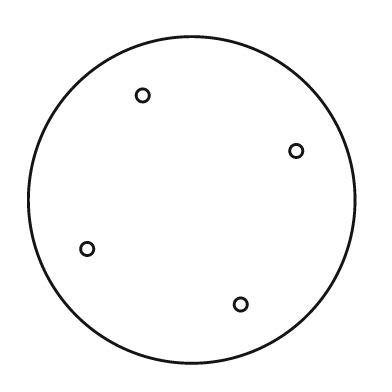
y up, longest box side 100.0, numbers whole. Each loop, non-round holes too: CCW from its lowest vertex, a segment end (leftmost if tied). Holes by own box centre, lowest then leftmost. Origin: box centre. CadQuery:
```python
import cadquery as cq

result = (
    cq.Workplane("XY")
    .moveTo(0.0, 0.0)
    .circle(50.0)
    .moveTo(15.0, -32.0)
    .circle(2.0)
    .moveTo(-32.0, -15.0)
    .circle(2.0)
    .moveTo(32.0, 15.0)
    .circle(2.0)
    .moveTo(-15.0, 32.0)
    .circle(2.0)
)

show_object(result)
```